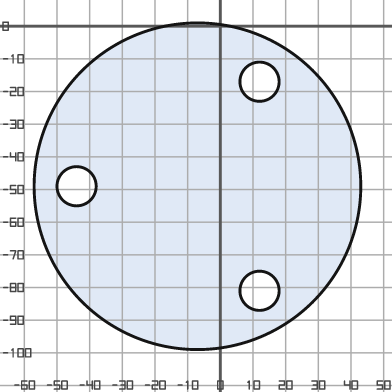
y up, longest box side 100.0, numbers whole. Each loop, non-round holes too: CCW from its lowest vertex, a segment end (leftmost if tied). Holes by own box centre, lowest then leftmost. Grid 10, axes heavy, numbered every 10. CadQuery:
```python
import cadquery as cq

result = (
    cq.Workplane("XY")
    .moveTo(-7.0, -49.0)
    .circle(50.0)
    .moveTo(12.0, -81.0)
    .circle(6.0)
    .moveTo(-44.0, -49.0)
    .circle(6.0)
    .moveTo(12.0, -17.0)
    .circle(6.0)
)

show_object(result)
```